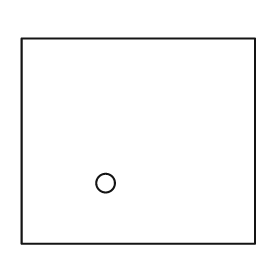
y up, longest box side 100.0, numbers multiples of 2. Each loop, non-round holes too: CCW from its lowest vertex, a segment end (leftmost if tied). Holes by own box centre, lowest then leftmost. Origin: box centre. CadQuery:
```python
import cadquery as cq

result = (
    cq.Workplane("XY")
    .moveTo(-50.0, -44.0)
    .lineTo(50.0, -44.0)
    .lineTo(50.0, 44.0)
    .lineTo(-50.0, 44.0)
    .close()
    .moveTo(-14.0, -18.0)
    .circle(4.0)
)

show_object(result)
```